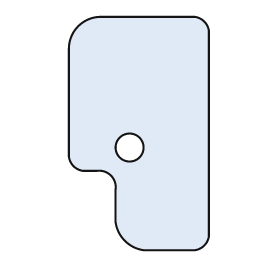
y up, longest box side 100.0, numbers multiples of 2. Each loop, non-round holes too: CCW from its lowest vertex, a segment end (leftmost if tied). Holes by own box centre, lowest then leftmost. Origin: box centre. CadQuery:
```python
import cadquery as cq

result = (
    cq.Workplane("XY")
    .moveTo(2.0, -50.0)
    .lineTo(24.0, -50.0)
    .threePointArc((28.0, -48.0), (30.0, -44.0))
    .lineTo(30.0, 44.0)
    .threePointArc((28.0, 48.0), (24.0, 50.0))
    .lineTo(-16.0, 50.0)
    .threePointArc((-26.0, 46.0), (-30.0, 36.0))
    .lineTo(-30.0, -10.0)
    .threePointArc((-28.0, -14.0), (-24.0, -16.0))
    .lineTo(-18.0, -16.0)
    .threePointArc((-12.0, -18.0), (-10.0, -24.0))
    .lineTo(-10.0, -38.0)
    .threePointArc((-6.0, -46.0), (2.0, -50.0))
    .close()
    .moveTo(-4.0, -6.0)
    .circle(6.0)
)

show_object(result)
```